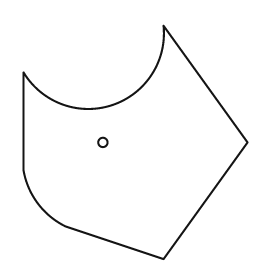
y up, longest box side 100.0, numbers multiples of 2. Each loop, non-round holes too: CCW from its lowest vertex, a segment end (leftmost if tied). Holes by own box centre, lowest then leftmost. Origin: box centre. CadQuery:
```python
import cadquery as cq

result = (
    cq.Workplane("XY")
    .moveTo(12.0, -50.0)
    .lineTo(48.0, 0.0)
    .lineTo(12.0, 50.0)
    .threePointArc((-10.0, 16.0), (-48.0, 30.0))
    .lineTo(-48.0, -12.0)
    .threePointArc((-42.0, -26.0), (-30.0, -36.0))
    .close()
    .moveTo(-14.0, 0.0)
    .circle(2.0)
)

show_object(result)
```